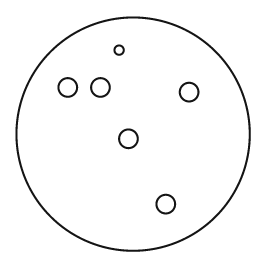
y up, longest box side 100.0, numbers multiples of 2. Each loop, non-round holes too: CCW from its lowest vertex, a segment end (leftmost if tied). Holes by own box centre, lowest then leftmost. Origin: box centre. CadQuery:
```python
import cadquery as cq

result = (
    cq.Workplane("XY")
    .moveTo(0.0, 0.0)
    .circle(50.0)
    .moveTo(14.0, -30.0)
    .circle(4.0)
    .moveTo(-2.0, -2.0)
    .circle(4.0)
    .moveTo(24.0, 18.0)
    .circle(4.0)
    .moveTo(-28.0, 20.0)
    .circle(4.0)
    .moveTo(-14.0, 20.0)
    .circle(4.0)
    .moveTo(-6.0, 36.0)
    .circle(2.0)
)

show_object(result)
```